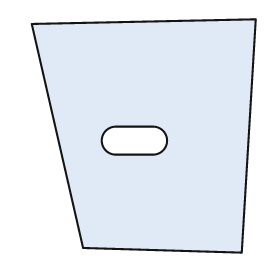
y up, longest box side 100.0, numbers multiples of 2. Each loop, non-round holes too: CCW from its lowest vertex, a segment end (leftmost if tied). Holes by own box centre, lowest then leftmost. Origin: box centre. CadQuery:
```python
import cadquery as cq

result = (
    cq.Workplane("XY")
    .moveTo(42.0, -50.0)
    .lineTo(48.0, 50.0)
    .lineTo(-48.0, 48.0)
    .lineTo(-26.0, -48.0)
    .close()
    .moveTo(-12.0, -8.0)
    .lineTo(4.0, -8.0)
    .threePointArc((10.0, -2.0), (4.0, 4.0))
    .lineTo(-12.0, 4.0)
    .threePointArc((-18.0, -2.0), (-12.0, -8.0))
    .close()
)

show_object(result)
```